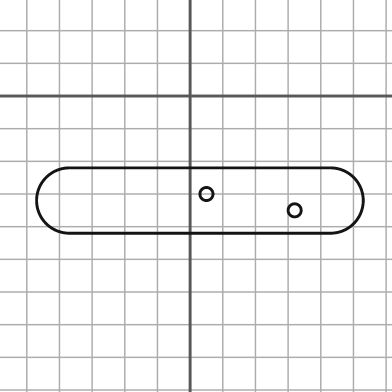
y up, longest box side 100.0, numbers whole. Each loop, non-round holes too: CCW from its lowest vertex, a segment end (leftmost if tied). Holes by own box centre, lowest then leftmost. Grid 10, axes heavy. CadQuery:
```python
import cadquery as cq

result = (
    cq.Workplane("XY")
    .moveTo(-37.0, -42.0)
    .lineTo(43.0, -42.0)
    .threePointArc((53.0, -32.0), (43.0, -22.0))
    .lineTo(-37.0, -22.0)
    .threePointArc((-47.0, -32.0), (-37.0, -42.0))
    .close()
    .moveTo(32.0, -35.0)
    .circle(2.0)
    .moveTo(5.0, -30.0)
    .circle(2.0)
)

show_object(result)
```